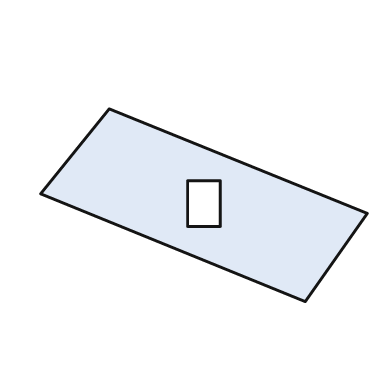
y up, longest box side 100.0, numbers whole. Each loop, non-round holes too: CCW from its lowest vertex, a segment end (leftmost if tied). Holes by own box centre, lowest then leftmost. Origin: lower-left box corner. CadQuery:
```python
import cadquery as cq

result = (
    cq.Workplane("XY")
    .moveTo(81.0, 0.0)
    .lineTo(100.0, 27.0)
    .lineTo(21.0, 59.0)
    .lineTo(0.0, 33.0)
    .close()
    .moveTo(45.0, 23.0)
    .lineTo(55.0, 23.0)
    .lineTo(55.0, 37.0)
    .lineTo(45.0, 37.0)
    .close()
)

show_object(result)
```